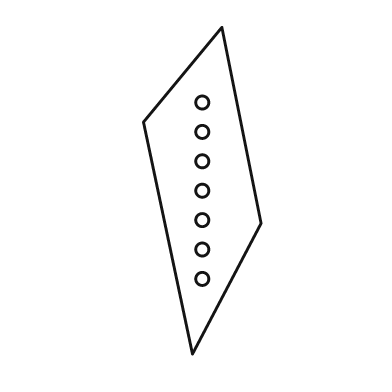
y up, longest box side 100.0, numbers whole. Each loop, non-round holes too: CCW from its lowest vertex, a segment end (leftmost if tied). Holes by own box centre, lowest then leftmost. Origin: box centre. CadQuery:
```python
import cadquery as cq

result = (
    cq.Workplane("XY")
    .moveTo(-3.0, -50.0)
    .lineTo(18.0, -10.0)
    .lineTo(6.0, 50.0)
    .lineTo(-18.0, 21.0)
    .close()
    .moveTo(0.0, -27.0)
    .circle(2.0)
    .moveTo(0.0, -18.0)
    .circle(2.0)
    .moveTo(0.0, -9.0)
    .circle(2.0)
    .moveTo(0.0, 0.0)
    .circle(2.0)
    .moveTo(0.0, 9.0)
    .circle(2.0)
    .moveTo(0.0, 18.0)
    .circle(2.0)
    .moveTo(0.0, 27.0)
    .circle(2.0)
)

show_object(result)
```